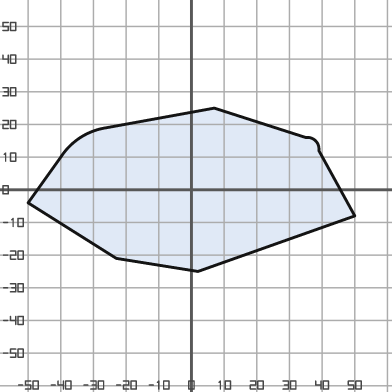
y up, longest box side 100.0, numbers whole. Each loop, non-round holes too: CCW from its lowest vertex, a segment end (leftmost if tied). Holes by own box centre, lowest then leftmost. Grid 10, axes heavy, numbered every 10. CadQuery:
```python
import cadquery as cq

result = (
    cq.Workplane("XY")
    .moveTo(2.0, -25.0)
    .lineTo(50.0, -8.0)
    .lineTo(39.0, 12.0)
    .threePointArc((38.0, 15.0), (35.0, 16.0))
    .lineTo(7.0, 25.0)
    .lineTo(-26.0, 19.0)
    .threePointArc((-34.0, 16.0), (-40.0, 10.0))
    .lineTo(-50.0, -4.0)
    .lineTo(-23.0, -21.0)
    .close()
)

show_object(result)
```